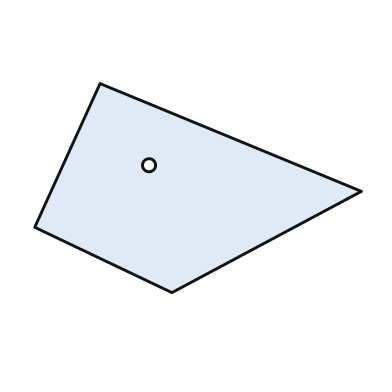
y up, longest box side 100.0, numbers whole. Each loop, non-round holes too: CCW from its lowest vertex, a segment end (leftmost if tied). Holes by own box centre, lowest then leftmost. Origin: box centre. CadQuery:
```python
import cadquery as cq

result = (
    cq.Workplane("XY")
    .moveTo(-8.0, -32.0)
    .lineTo(50.0, -1.0)
    .lineTo(-30.0, 32.0)
    .lineTo(-50.0, -12.0)
    .close()
    .moveTo(-15.0, 7.0)
    .circle(2.0)
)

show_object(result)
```